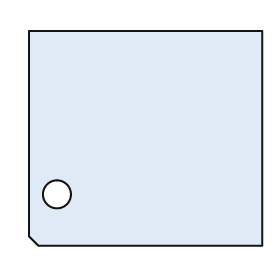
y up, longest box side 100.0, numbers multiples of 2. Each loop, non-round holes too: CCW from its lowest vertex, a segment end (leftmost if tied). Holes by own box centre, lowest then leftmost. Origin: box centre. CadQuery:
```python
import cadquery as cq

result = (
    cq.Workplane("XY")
    .moveTo(-46.0, -46.0)
    .lineTo(50.0, -46.0)
    .lineTo(50.0, 46.0)
    .lineTo(-50.0, 46.0)
    .lineTo(-50.0, -42.0)
    .close()
    .moveTo(-38.0, -24.0)
    .circle(6.0)
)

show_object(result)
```